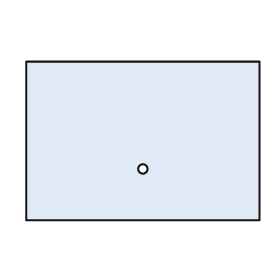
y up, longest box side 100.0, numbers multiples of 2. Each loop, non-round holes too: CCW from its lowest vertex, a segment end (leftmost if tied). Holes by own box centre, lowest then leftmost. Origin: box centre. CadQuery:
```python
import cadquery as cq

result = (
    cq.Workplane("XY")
    .moveTo(-50.0, -34.0)
    .lineTo(50.0, -34.0)
    .lineTo(50.0, 34.0)
    .lineTo(-50.0, 34.0)
    .close()
    .moveTo(0.0, -12.0)
    .circle(2.0)
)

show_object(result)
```